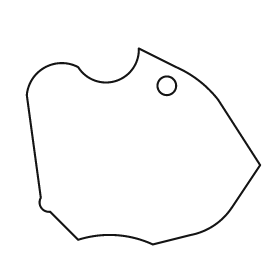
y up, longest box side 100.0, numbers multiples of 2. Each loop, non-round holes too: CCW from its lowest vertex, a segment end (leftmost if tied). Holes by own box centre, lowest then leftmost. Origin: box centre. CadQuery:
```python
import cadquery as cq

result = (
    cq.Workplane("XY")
    .moveTo(4.0, -42.0)
    .lineTo(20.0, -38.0)
    .threePointArc((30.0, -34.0), (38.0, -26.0))
    .lineTo(50.0, -8.0)
    .lineTo(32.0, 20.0)
    .threePointArc((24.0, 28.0), (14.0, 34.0))
    .lineTo(-2.0, 42.0)
    .threePointArc((-12.0, 28.0), (-28.0, 34.0))
    .threePointArc((-42.0, 34.0), (-50.0, 22.0))
    .lineTo(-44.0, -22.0)
    .threePointArc((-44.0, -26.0), (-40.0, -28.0))
    .lineTo(-28.0, -40.0)
    .threePointArc((-12.0, -38.0), (4.0, -42.0))
    .close()
    .moveTo(10.0, 26.0)
    .circle(4.0)
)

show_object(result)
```